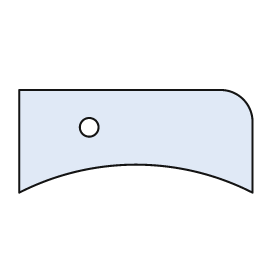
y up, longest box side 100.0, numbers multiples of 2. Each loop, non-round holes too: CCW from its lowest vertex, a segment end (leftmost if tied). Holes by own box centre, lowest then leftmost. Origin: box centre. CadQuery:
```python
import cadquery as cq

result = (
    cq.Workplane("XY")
    .moveTo(-50.0, -22.0)
    .threePointArc((0.0, -10.0), (50.0, -22.0))
    .lineTo(50.0, 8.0)
    .threePointArc((46.0, 18.0), (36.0, 22.0))
    .lineTo(-50.0, 22.0)
    .close()
    .moveTo(-20.0, 6.0)
    .circle(4.0)
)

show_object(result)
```